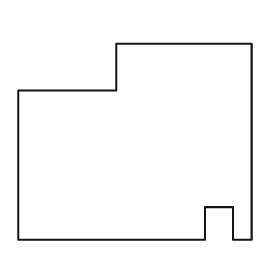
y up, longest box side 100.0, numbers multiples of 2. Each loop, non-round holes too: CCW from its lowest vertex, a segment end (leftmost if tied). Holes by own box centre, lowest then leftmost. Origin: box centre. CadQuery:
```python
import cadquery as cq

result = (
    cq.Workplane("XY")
    .moveTo(-50.0, -42.0)
    .lineTo(30.0, -42.0)
    .lineTo(30.0, -28.0)
    .lineTo(42.0, -28.0)
    .lineTo(42.0, -42.0)
    .lineTo(50.0, -42.0)
    .lineTo(50.0, 42.0)
    .lineTo(-8.0, 42.0)
    .lineTo(-8.0, 22.0)
    .lineTo(-50.0, 22.0)
    .close()
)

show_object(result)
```